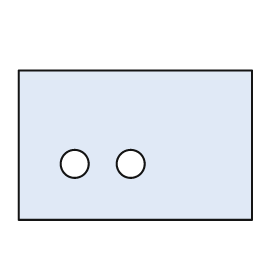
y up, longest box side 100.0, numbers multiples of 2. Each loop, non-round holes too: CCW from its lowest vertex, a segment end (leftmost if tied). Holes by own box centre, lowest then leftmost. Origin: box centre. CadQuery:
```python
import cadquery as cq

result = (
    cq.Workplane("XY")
    .moveTo(-50.0, -32.0)
    .lineTo(50.0, -32.0)
    .lineTo(50.0, 32.0)
    .lineTo(-50.0, 32.0)
    .close()
    .moveTo(-26.0, -8.0)
    .circle(6.0)
    .moveTo(-2.0, -8.0)
    .circle(6.0)
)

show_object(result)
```